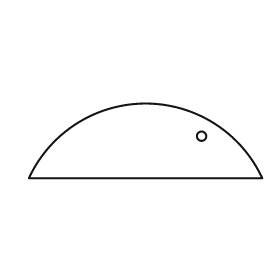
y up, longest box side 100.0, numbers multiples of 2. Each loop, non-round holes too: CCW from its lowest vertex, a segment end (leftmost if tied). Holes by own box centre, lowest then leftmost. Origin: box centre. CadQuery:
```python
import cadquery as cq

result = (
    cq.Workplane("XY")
    .moveTo(-50.0, -16.0)
    .lineTo(50.0, -16.0)
    .threePointArc((0.0, 16.0), (-50.0, -16.0))
    .close()
    .moveTo(24.0, 2.0)
    .circle(2.0)
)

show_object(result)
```